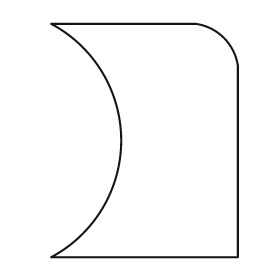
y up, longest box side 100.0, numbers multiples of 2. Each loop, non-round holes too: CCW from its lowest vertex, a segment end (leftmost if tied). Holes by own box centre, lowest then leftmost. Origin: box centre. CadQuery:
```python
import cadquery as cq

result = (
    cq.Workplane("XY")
    .moveTo(-40.0, -50.0)
    .lineTo(40.0, -50.0)
    .lineTo(40.0, 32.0)
    .threePointArc((34.0, 44.0), (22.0, 50.0))
    .lineTo(-40.0, 50.0)
    .threePointArc((-10.0, 0.0), (-40.0, -50.0))
    .close()
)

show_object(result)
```